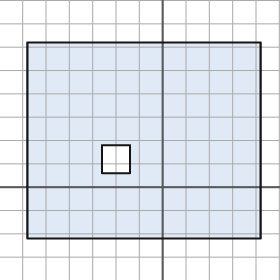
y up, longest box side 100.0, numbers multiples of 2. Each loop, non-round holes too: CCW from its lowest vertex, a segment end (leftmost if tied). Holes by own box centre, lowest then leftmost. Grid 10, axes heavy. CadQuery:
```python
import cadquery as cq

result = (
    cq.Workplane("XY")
    .moveTo(-58.0, -22.0)
    .lineTo(42.0, -22.0)
    .lineTo(42.0, 62.0)
    .lineTo(-58.0, 62.0)
    .close()
    .moveTo(-26.0, 6.0)
    .lineTo(-14.0, 6.0)
    .lineTo(-14.0, 18.0)
    .lineTo(-26.0, 18.0)
    .close()
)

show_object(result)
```